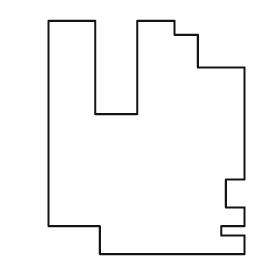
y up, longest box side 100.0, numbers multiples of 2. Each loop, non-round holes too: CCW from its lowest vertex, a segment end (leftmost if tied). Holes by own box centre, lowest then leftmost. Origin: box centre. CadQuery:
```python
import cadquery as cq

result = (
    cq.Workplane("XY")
    .moveTo(-20.0, -50.0)
    .lineTo(42.0, -50.0)
    .lineTo(42.0, -42.0)
    .lineTo(32.0, -42.0)
    .lineTo(32.0, -38.0)
    .lineTo(42.0, -38.0)
    .lineTo(42.0, -30.0)
    .lineTo(34.0, -30.0)
    .lineTo(34.0, -18.0)
    .lineTo(42.0, -18.0)
    .lineTo(42.0, 30.0)
    .lineTo(22.0, 30.0)
    .lineTo(22.0, 44.0)
    .lineTo(12.0, 44.0)
    .lineTo(12.0, 50.0)
    .lineTo(-4.0, 50.0)
    .lineTo(-4.0, 10.0)
    .lineTo(-22.0, 10.0)
    .lineTo(-22.0, 50.0)
    .lineTo(-42.0, 50.0)
    .lineTo(-42.0, -38.0)
    .lineTo(-20.0, -38.0)
    .close()
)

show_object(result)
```